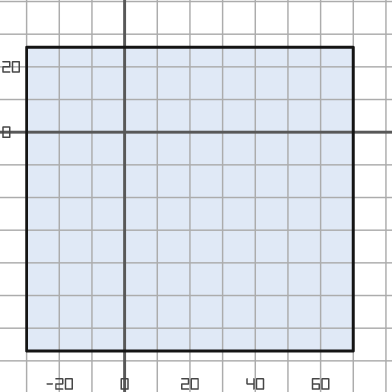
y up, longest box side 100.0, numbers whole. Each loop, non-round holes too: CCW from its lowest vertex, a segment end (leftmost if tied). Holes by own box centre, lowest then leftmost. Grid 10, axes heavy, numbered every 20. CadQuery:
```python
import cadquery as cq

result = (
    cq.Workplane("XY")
    .moveTo(-30.0, -67.0)
    .lineTo(70.0, -67.0)
    .lineTo(70.0, 26.0)
    .lineTo(-30.0, 26.0)
    .close()
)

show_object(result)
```